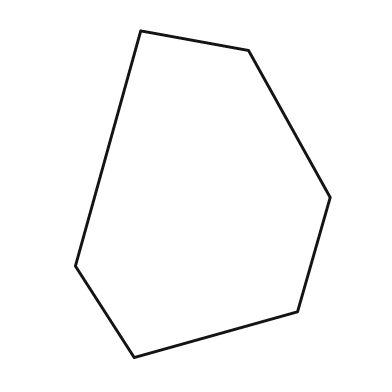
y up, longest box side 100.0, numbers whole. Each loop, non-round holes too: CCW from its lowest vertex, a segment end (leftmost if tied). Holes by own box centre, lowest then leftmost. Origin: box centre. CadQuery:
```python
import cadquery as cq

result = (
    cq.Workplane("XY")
    .moveTo(-21.0, -50.0)
    .lineTo(29.0, -36.0)
    .lineTo(39.0, -1.0)
    .lineTo(14.0, 44.0)
    .lineTo(-19.0, 50.0)
    .lineTo(-39.0, -22.0)
    .close()
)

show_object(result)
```